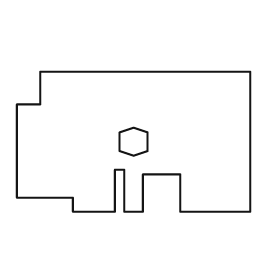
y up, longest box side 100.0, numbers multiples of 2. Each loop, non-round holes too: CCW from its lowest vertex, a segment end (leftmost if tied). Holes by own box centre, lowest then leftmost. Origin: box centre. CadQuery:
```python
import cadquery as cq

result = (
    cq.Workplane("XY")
    .moveTo(-26.0, -30.0)
    .lineTo(-8.0, -30.0)
    .lineTo(-8.0, -12.0)
    .lineTo(-4.0, -12.0)
    .lineTo(-4.0, -30.0)
    .lineTo(4.0, -30.0)
    .lineTo(4.0, -14.0)
    .lineTo(20.0, -14.0)
    .lineTo(20.0, -30.0)
    .lineTo(50.0, -30.0)
    .lineTo(50.0, 30.0)
    .lineTo(-40.0, 30.0)
    .lineTo(-40.0, 16.0)
    .lineTo(-50.0, 16.0)
    .lineTo(-50.0, -24.0)
    .lineTo(-26.0, -24.0)
    .close()
    .moveTo(0.0, -6.0)
    .lineTo(6.0, -4.0)
    .lineTo(6.0, 4.0)
    .lineTo(0.0, 6.0)
    .lineTo(-6.0, 4.0)
    .lineTo(-6.0, -4.0)
    .close()
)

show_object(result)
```